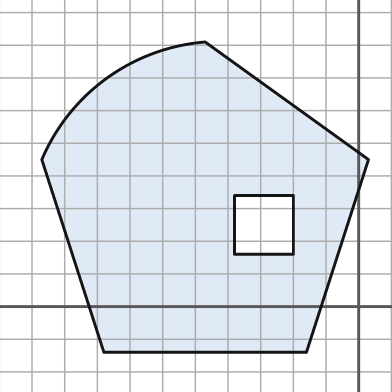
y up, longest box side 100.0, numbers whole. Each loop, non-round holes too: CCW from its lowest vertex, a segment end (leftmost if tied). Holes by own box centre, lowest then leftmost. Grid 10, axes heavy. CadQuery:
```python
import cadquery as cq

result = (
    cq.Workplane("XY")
    .moveTo(-78.0, -14.0)
    .lineTo(-16.0, -14.0)
    .lineTo(3.0, 45.0)
    .lineTo(-47.0, 81.0)
    .threePointArc((-77.0, 70.0), (-97.0, 45.0))
    .close()
    .moveTo(-38.0, 16.0)
    .lineTo(-20.0, 16.0)
    .lineTo(-20.0, 34.0)
    .lineTo(-38.0, 34.0)
    .close()
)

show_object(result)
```